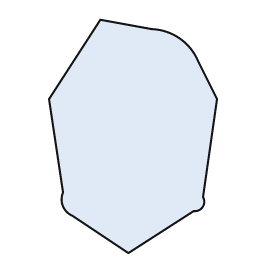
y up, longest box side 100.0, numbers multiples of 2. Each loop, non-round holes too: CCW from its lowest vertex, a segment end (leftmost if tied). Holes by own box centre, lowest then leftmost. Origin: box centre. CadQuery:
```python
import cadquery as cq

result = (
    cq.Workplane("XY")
    .moveTo(-2.0, -50.0)
    .lineTo(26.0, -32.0)
    .threePointArc((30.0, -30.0), (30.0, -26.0))
    .lineTo(36.0, 16.0)
    .lineTo(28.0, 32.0)
    .threePointArc((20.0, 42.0), (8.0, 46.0))
    .lineTo(-14.0, 50.0)
    .lineTo(-36.0, 16.0)
    .lineTo(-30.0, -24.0)
    .threePointArc((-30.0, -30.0), (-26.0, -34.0))
    .close()
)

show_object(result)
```